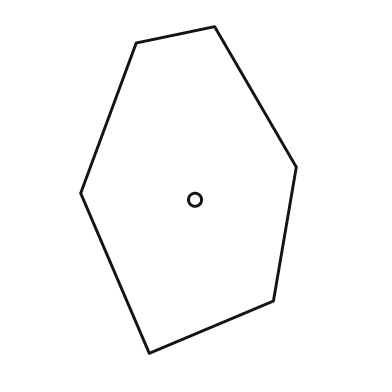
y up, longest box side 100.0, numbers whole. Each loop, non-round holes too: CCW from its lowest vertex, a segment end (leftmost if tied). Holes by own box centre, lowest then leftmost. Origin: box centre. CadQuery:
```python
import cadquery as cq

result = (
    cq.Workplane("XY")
    .moveTo(-12.0, -50.0)
    .lineTo(26.0, -34.0)
    .lineTo(33.0, 7.0)
    .lineTo(8.0, 50.0)
    .lineTo(-16.0, 45.0)
    .lineTo(-33.0, -1.0)
    .close()
    .moveTo(2.0, -3.0)
    .circle(2.0)
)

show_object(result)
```